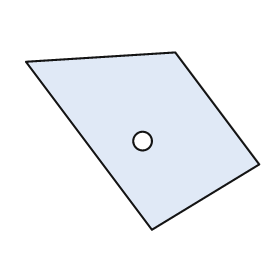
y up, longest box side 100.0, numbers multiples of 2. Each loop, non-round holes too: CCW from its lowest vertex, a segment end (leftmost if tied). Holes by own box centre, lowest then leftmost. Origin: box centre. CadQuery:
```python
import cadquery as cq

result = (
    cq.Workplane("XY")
    .moveTo(4.0, -38.0)
    .lineTo(50.0, -10.0)
    .lineTo(14.0, 38.0)
    .lineTo(-50.0, 34.0)
    .close()
    .moveTo(0.0, 0.0)
    .circle(4.0)
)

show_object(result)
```